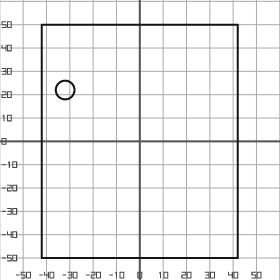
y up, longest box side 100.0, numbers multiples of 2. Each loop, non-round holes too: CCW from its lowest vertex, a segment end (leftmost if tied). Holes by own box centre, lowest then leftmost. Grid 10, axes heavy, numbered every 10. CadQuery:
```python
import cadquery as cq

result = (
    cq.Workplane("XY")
    .moveTo(-42.0, -50.0)
    .lineTo(42.0, -50.0)
    .lineTo(42.0, 50.0)
    .lineTo(-42.0, 50.0)
    .close()
    .moveTo(-32.0, 22.0)
    .circle(4.0)
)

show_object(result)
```